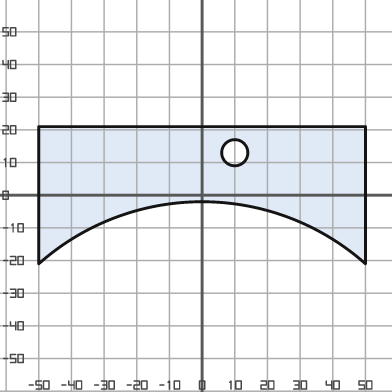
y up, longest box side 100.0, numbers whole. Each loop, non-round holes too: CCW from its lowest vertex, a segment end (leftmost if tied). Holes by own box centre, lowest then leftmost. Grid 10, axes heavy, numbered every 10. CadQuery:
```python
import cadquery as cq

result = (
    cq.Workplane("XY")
    .moveTo(-50.0, -21.0)
    .threePointArc((0.0, -2.0), (50.0, -21.0))
    .lineTo(50.0, 21.0)
    .lineTo(-50.0, 21.0)
    .close()
    .moveTo(10.0, 13.0)
    .circle(4.0)
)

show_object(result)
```